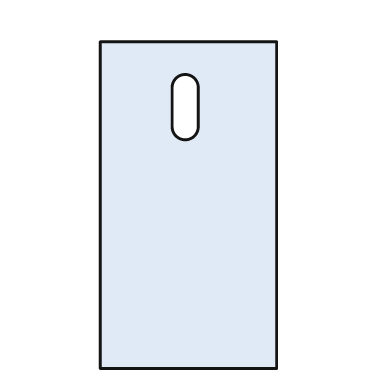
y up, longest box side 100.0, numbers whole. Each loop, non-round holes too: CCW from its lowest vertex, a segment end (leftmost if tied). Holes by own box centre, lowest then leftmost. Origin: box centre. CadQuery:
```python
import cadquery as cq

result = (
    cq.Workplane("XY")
    .moveTo(-27.0, -50.0)
    .lineTo(27.0, -50.0)
    .lineTo(27.0, 50.0)
    .lineTo(-27.0, 50.0)
    .close()
    .moveTo(-5.0, 24.0)
    .threePointArc((-1.0, 20.0), (3.0, 24.0))
    .lineTo(3.0, 36.0)
    .threePointArc((-1.0, 40.0), (-5.0, 36.0))
    .close()
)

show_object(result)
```